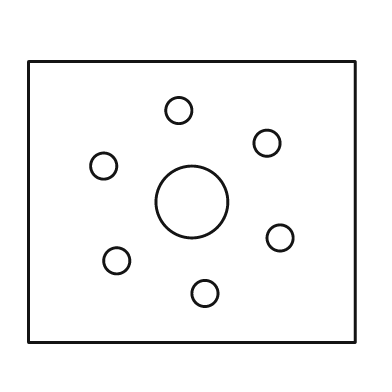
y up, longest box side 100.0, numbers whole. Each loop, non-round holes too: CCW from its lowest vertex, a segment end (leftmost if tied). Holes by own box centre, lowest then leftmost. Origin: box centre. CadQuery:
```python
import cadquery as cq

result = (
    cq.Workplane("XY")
    .moveTo(-50.0, -43.0)
    .lineTo(50.0, -43.0)
    .lineTo(50.0, 43.0)
    .lineTo(-50.0, 43.0)
    .close()
    .moveTo(4.0, -28.0)
    .circle(4.0)
    .moveTo(-23.0, -18.0)
    .circle(4.0)
    .moveTo(27.0, -11.0)
    .circle(4.0)
    .moveTo(0.0, 0.0)
    .circle(11.0)
    .moveTo(-27.0, 11.0)
    .circle(4.0)
    .moveTo(23.0, 18.0)
    .circle(4.0)
    .moveTo(-4.0, 28.0)
    .circle(4.0)
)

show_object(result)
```